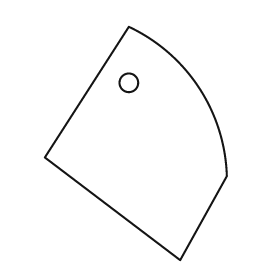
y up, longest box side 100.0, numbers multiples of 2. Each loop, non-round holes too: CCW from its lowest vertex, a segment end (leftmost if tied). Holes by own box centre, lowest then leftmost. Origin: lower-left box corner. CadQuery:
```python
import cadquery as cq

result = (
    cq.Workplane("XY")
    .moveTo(58.0, 0.0)
    .lineTo(78.0, 36.0)
    .threePointArc((66.0, 74.0), (36.0, 100.0))
    .lineTo(0.0, 44.0)
    .close()
    .moveTo(36.0, 76.0)
    .circle(4.0)
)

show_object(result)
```